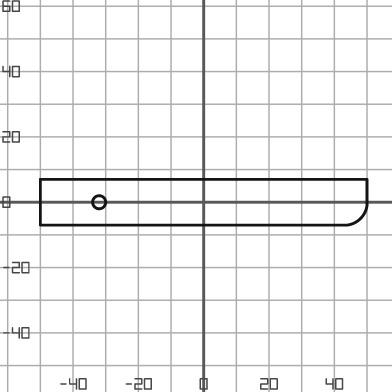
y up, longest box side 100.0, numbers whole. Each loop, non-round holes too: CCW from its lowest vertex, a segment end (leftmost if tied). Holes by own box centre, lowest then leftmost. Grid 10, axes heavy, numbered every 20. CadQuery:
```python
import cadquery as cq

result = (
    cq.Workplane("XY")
    .moveTo(-50.0, -7.0)
    .lineTo(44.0, -7.0)
    .threePointArc((48.0, -5.0), (50.0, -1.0))
    .lineTo(50.0, 7.0)
    .lineTo(-50.0, 7.0)
    .close()
    .moveTo(-32.0, 0.0)
    .circle(2.0)
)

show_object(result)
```